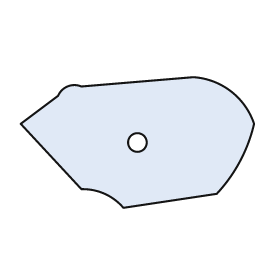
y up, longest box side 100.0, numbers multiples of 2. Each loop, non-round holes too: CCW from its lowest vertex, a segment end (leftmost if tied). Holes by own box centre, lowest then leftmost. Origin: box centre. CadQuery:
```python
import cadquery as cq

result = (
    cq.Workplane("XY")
    .moveTo(-6.0, -28.0)
    .lineTo(34.0, -22.0)
    .threePointArc((44.0, -8.0), (50.0, 8.0))
    .threePointArc((40.0, 22.0), (24.0, 28.0))
    .lineTo(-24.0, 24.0)
    .threePointArc((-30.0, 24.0), (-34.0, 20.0))
    .lineTo(-50.0, 8.0)
    .lineTo(-24.0, -20.0)
    .threePointArc((-14.0, -22.0), (-6.0, -28.0))
    .close()
    .moveTo(0.0, 0.0)
    .circle(4.0)
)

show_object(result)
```